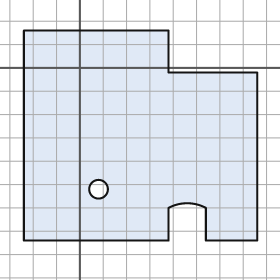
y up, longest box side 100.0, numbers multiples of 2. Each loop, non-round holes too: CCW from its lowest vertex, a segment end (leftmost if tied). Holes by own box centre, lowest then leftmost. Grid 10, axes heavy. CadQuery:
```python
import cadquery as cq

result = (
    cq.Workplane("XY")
    .moveTo(-24.0, -74.0)
    .lineTo(38.0, -74.0)
    .lineTo(38.0, -60.0)
    .threePointArc((46.0, -58.0), (54.0, -60.0))
    .lineTo(54.0, -74.0)
    .lineTo(76.0, -74.0)
    .lineTo(76.0, -2.0)
    .lineTo(38.0, -2.0)
    .lineTo(38.0, 16.0)
    .lineTo(-24.0, 16.0)
    .close()
    .moveTo(8.0, -52.0)
    .circle(4.0)
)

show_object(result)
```